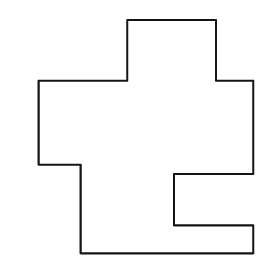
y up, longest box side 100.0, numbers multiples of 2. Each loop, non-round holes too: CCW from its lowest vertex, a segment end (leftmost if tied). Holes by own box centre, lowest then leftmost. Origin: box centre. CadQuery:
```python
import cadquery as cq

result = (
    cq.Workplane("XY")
    .moveTo(-28.0, -50.0)
    .lineTo(46.0, -50.0)
    .lineTo(46.0, -38.0)
    .lineTo(12.0, -38.0)
    .lineTo(12.0, -16.0)
    .lineTo(46.0, -16.0)
    .lineTo(46.0, 24.0)
    .lineTo(30.0, 24.0)
    .lineTo(30.0, 50.0)
    .lineTo(-8.0, 50.0)
    .lineTo(-8.0, 24.0)
    .lineTo(-46.0, 24.0)
    .lineTo(-46.0, -12.0)
    .lineTo(-28.0, -12.0)
    .close()
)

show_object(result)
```